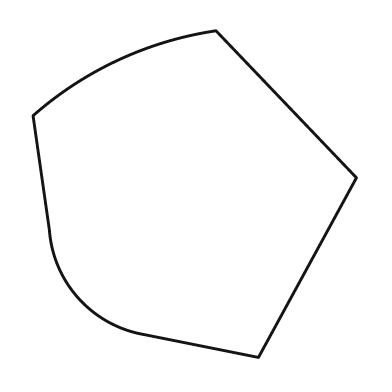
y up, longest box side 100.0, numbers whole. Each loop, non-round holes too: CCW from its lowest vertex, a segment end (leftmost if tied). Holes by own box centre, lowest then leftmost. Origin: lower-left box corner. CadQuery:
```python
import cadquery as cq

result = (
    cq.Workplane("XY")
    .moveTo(69.0, 0.0)
    .lineTo(99.0, 55.0)
    .lineTo(56.0, 100.0)
    .threePointArc((26.0, 91.0), (0.0, 74.0))
    .lineTo(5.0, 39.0)
    .threePointArc((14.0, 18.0), (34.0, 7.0))
    .close()
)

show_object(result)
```